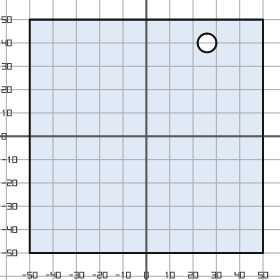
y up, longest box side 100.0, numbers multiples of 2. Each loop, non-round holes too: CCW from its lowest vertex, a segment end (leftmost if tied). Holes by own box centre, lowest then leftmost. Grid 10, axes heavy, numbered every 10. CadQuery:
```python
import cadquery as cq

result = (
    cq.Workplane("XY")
    .moveTo(-50.0, -50.0)
    .lineTo(50.0, -50.0)
    .lineTo(50.0, 50.0)
    .lineTo(-50.0, 50.0)
    .close()
    .moveTo(26.0, 40.0)
    .circle(4.0)
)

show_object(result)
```